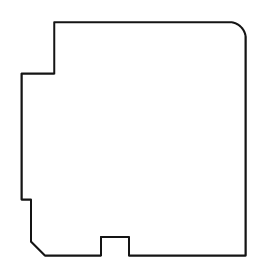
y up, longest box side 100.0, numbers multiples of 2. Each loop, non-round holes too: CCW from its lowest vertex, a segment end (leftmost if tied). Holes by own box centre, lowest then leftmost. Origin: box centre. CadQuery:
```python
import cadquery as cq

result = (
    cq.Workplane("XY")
    .moveTo(-38.0, -50.0)
    .lineTo(-14.0, -50.0)
    .lineTo(-14.0, -42.0)
    .lineTo(-2.0, -42.0)
    .lineTo(-2.0, -50.0)
    .lineTo(48.0, -50.0)
    .lineTo(48.0, 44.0)
    .threePointArc((46.0, 48.0), (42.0, 50.0))
    .lineTo(-34.0, 50.0)
    .lineTo(-34.0, 28.0)
    .lineTo(-48.0, 28.0)
    .lineTo(-48.0, -26.0)
    .lineTo(-44.0, -26.0)
    .lineTo(-44.0, -44.0)
    .close()
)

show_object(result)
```